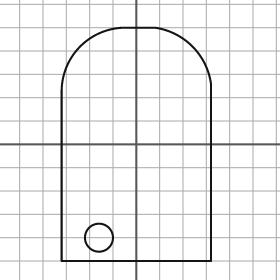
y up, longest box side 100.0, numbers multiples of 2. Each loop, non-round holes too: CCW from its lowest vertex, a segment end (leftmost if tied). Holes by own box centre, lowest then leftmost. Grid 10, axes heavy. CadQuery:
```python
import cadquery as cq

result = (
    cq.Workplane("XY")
    .moveTo(-32.0, -50.0)
    .lineTo(32.0, -50.0)
    .lineTo(32.0, 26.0)
    .threePointArc((24.0, 42.0), (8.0, 50.0))
    .lineTo(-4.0, 50.0)
    .threePointArc((-24.0, 42.0), (-32.0, 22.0))
    .close()
    .moveTo(-16.0, -40.0)
    .circle(6.0)
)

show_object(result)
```